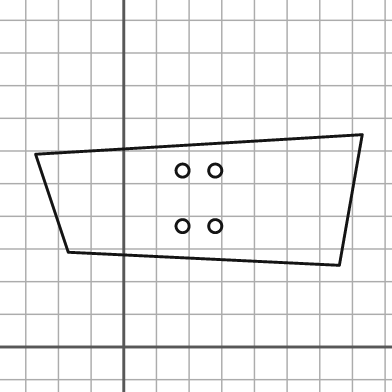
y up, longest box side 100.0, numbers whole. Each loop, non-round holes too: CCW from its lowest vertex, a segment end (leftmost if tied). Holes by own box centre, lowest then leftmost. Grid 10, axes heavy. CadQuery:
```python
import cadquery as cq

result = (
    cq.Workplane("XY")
    .moveTo(66.0, 25.0)
    .lineTo(73.0, 65.0)
    .lineTo(-27.0, 59.0)
    .lineTo(-17.0, 29.0)
    .close()
    .moveTo(18.0, 37.0)
    .circle(2.0)
    .moveTo(28.0, 37.0)
    .circle(2.0)
    .moveTo(18.0, 54.0)
    .circle(2.0)
    .moveTo(28.0, 54.0)
    .circle(2.0)
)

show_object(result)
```